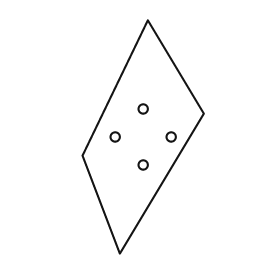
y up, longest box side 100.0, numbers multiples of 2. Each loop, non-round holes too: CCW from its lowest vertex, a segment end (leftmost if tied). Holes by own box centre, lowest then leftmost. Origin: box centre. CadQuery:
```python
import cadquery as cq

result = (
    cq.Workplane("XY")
    .moveTo(-10.0, -50.0)
    .lineTo(26.0, 10.0)
    .lineTo(2.0, 50.0)
    .lineTo(-26.0, -8.0)
    .close()
    .moveTo(0.0, -12.0)
    .circle(2.0)
    .moveTo(-12.0, 0.0)
    .circle(2.0)
    .moveTo(12.0, 0.0)
    .circle(2.0)
    .moveTo(0.0, 12.0)
    .circle(2.0)
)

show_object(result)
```